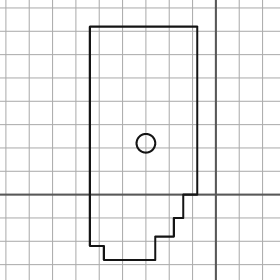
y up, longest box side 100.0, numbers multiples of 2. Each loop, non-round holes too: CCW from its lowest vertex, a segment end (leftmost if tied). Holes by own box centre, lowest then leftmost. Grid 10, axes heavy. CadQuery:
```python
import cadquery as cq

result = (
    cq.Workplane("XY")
    .moveTo(-48.0, -28.0)
    .lineTo(-26.0, -28.0)
    .lineTo(-26.0, -18.0)
    .lineTo(-18.0, -18.0)
    .lineTo(-18.0, -10.0)
    .lineTo(-14.0, -10.0)
    .lineTo(-14.0, 0.0)
    .lineTo(-8.0, 0.0)
    .lineTo(-8.0, 72.0)
    .lineTo(-54.0, 72.0)
    .lineTo(-54.0, -22.0)
    .lineTo(-48.0, -22.0)
    .close()
    .moveTo(-30.0, 22.0)
    .circle(4.0)
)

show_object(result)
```